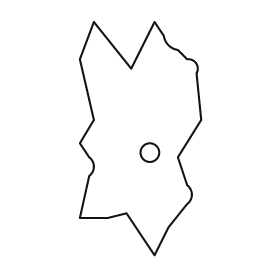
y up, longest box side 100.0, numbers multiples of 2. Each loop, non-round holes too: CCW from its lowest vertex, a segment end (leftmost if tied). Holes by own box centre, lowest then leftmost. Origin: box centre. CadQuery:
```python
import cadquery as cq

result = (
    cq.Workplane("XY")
    .moveTo(6.0, -50.0)
    .lineTo(12.0, -38.0)
    .lineTo(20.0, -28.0)
    .threePointArc((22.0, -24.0), (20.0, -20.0))
    .lineTo(16.0, -8.0)
    .lineTo(26.0, 8.0)
    .lineTo(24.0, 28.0)
    .threePointArc((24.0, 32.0), (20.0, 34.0))
    .lineTo(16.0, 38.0)
    .threePointArc((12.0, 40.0), (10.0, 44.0))
    .lineTo(6.0, 50.0)
    .lineTo(-4.0, 30.0)
    .lineTo(-20.0, 50.0)
    .lineTo(-26.0, 34.0)
    .lineTo(-20.0, 8.0)
    .lineTo(-26.0, -2.0)
    .lineTo(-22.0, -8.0)
    .threePointArc((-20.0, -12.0), (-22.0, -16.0))
    .lineTo(-26.0, -34.0)
    .lineTo(-14.0, -34.0)
    .lineTo(-6.0, -32.0)
    .close()
    .moveTo(4.0, -6.0)
    .circle(4.0)
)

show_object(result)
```